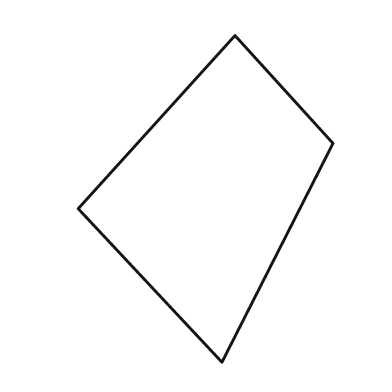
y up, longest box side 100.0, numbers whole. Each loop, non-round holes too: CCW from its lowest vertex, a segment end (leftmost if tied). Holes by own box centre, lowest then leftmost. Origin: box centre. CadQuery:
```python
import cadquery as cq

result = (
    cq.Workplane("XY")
    .moveTo(5.0, -50.0)
    .lineTo(39.0, 17.0)
    .lineTo(9.0, 50.0)
    .lineTo(-39.0, -3.0)
    .close()
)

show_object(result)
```